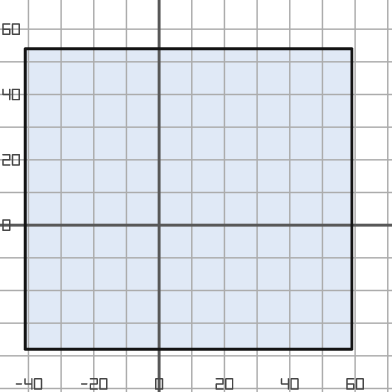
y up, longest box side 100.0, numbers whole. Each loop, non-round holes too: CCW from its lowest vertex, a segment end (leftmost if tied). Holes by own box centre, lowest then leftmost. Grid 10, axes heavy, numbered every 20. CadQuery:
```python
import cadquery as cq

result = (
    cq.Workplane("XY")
    .moveTo(-41.0, -38.0)
    .lineTo(59.0, -38.0)
    .lineTo(59.0, 54.0)
    .lineTo(-41.0, 54.0)
    .close()
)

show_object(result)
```